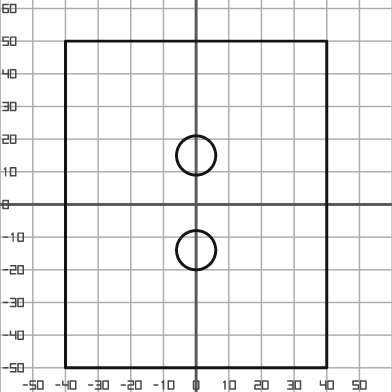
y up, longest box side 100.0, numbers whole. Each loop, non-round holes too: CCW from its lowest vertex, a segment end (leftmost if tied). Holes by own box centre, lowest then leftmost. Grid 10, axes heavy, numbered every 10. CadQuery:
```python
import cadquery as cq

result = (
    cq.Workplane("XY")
    .moveTo(-40.0, -50.0)
    .lineTo(40.0, -50.0)
    .lineTo(40.0, 50.0)
    .lineTo(-40.0, 50.0)
    .close()
    .moveTo(0.0, -14.0)
    .circle(6.0)
    .moveTo(0.0, 15.0)
    .circle(6.0)
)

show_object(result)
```